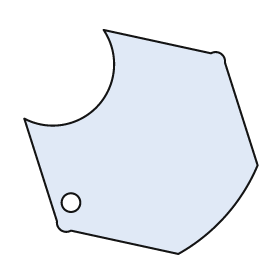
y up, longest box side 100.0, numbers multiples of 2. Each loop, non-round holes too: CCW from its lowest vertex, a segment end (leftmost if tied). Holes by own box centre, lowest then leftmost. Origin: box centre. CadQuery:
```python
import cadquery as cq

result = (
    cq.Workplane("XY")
    .moveTo(16.0, -48.0)
    .threePointArc((36.0, -32.0), (50.0, -10.0))
    .lineTo(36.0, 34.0)
    .threePointArc((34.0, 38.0), (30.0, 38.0))
    .lineTo(-16.0, 48.0)
    .threePointArc((-18.0, 16.0), (-50.0, 10.0))
    .lineTo(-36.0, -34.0)
    .threePointArc((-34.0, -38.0), (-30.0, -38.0))
    .close()
    .moveTo(-30.0, -26.0)
    .circle(4.0)
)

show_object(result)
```